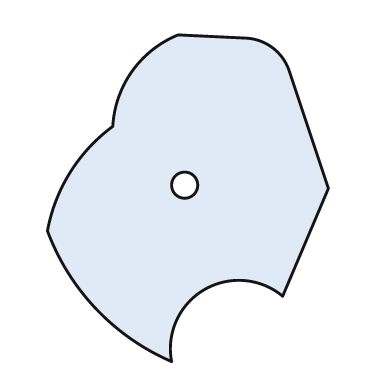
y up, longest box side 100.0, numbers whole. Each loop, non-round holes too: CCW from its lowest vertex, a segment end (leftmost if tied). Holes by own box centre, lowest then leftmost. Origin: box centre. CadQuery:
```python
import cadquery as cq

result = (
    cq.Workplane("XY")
    .moveTo(-5.0, -50.0)
    .threePointArc((5.0, -28.0), (29.0, -30.0))
    .lineTo(43.0, 3.0)
    .lineTo(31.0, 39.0)
    .threePointArc((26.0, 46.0), (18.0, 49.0))
    .lineTo(-3.0, 50.0)
    .threePointArc((-17.0, 39.0), (-23.0, 22.0))
    .threePointArc((-36.0, 8.0), (-43.0, -10.0))
    .threePointArc((-28.0, -34.0), (-5.0, -50.0))
    .close()
    .moveTo(-1.0, 4.0)
    .circle(4.0)
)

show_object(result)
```